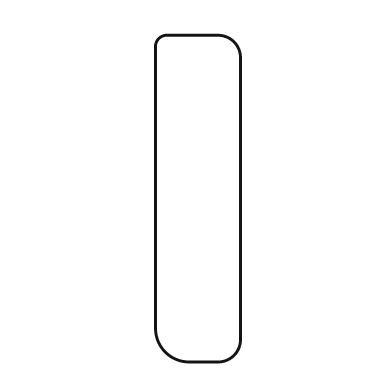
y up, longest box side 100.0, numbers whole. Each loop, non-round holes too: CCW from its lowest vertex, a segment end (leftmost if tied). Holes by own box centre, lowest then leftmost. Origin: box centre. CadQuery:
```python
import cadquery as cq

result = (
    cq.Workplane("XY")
    .moveTo(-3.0, -50.0)
    .lineTo(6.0, -50.0)
    .threePointArc((11.0, -48.0), (13.0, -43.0))
    .lineTo(13.0, 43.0)
    .threePointArc((11.0, 48.0), (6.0, 50.0))
    .lineTo(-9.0, 50.0)
    .threePointArc((-12.0, 49.0), (-13.0, 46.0))
    .lineTo(-13.0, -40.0)
    .threePointArc((-10.0, -47.0), (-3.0, -50.0))
    .close()
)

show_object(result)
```